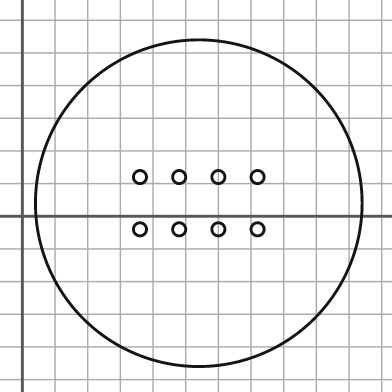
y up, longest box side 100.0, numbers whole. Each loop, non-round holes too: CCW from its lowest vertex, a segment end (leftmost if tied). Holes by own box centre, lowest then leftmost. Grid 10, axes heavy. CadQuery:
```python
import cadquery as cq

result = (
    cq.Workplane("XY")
    .moveTo(54.0, 4.0)
    .circle(50.0)
    .moveTo(36.0, -4.0)
    .circle(2.0)
    .moveTo(48.0, -4.0)
    .circle(2.0)
    .moveTo(60.0, -4.0)
    .circle(2.0)
    .moveTo(72.0, -4.0)
    .circle(2.0)
    .moveTo(36.0, 12.0)
    .circle(2.0)
    .moveTo(48.0, 12.0)
    .circle(2.0)
    .moveTo(60.0, 12.0)
    .circle(2.0)
    .moveTo(72.0, 12.0)
    .circle(2.0)
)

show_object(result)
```